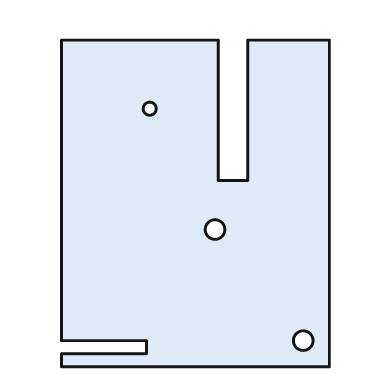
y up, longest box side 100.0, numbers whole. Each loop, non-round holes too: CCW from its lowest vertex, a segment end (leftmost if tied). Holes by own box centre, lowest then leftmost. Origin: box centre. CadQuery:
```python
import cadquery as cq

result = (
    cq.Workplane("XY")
    .moveTo(-41.0, -50.0)
    .lineTo(41.0, -50.0)
    .lineTo(41.0, 50.0)
    .lineTo(16.0, 50.0)
    .lineTo(16.0, 7.0)
    .lineTo(7.0, 7.0)
    .lineTo(7.0, 50.0)
    .lineTo(-41.0, 50.0)
    .lineTo(-41.0, -42.0)
    .lineTo(-15.0, -42.0)
    .lineTo(-15.0, -46.0)
    .lineTo(-41.0, -46.0)
    .close()
    .moveTo(33.0, -42.0)
    .circle(3.0)
    .moveTo(6.0, -8.0)
    .circle(3.0)
    .moveTo(-14.0, 29.0)
    .circle(2.0)
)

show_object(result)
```